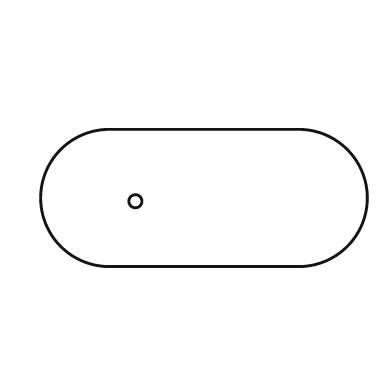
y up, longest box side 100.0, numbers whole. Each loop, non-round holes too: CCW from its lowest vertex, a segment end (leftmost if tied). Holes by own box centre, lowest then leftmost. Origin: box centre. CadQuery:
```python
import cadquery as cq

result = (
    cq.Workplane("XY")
    .moveTo(-29.0, -21.0)
    .lineTo(29.0, -21.0)
    .threePointArc((50.0, 0.0), (29.0, 21.0))
    .lineTo(-29.0, 21.0)
    .threePointArc((-50.0, 0.0), (-29.0, -21.0))
    .close()
    .moveTo(-21.0, -1.0)
    .circle(2.0)
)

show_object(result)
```